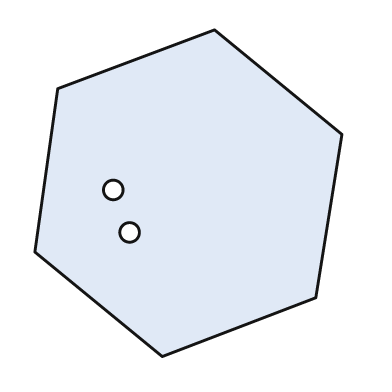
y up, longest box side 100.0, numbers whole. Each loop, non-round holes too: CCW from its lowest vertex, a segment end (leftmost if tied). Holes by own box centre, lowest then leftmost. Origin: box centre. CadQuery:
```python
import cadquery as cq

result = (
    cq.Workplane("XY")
    .moveTo(-8.0, -50.0)
    .lineTo(39.0, -32.0)
    .lineTo(47.0, 18.0)
    .lineTo(8.0, 50.0)
    .lineTo(-40.0, 32.0)
    .lineTo(-47.0, -18.0)
    .close()
    .moveTo(-18.0, -12.0)
    .circle(3.0)
    .moveTo(-23.0, 1.0)
    .circle(3.0)
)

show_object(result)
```